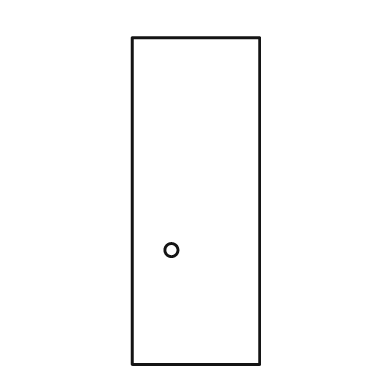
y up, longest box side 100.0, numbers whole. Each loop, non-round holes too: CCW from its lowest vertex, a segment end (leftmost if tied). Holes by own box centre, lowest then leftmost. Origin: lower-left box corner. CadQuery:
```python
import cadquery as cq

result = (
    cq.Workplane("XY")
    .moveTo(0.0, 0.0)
    .lineTo(39.0, 0.0)
    .lineTo(39.0, 100.0)
    .lineTo(0.0, 100.0)
    .close()
    .moveTo(12.0, 35.0)
    .circle(2.0)
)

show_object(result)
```